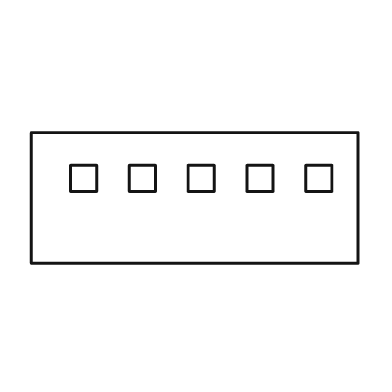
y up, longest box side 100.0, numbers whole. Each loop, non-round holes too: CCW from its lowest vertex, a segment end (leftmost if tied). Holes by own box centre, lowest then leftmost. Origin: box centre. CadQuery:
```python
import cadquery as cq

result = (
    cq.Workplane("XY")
    .moveTo(-50.0, -20.0)
    .lineTo(50.0, -20.0)
    .lineTo(50.0, 20.0)
    .lineTo(-50.0, 20.0)
    .close()
    .moveTo(-38.0, 2.0)
    .lineTo(-30.0, 2.0)
    .lineTo(-30.0, 10.0)
    .lineTo(-38.0, 10.0)
    .close()
    .moveTo(-20.0, 2.0)
    .lineTo(-12.0, 2.0)
    .lineTo(-12.0, 10.0)
    .lineTo(-20.0, 10.0)
    .close()
    .moveTo(-2.0, 2.0)
    .lineTo(6.0, 2.0)
    .lineTo(6.0, 10.0)
    .lineTo(-2.0, 10.0)
    .close()
    .moveTo(16.0, 2.0)
    .lineTo(24.0, 2.0)
    .lineTo(24.0, 10.0)
    .lineTo(16.0, 10.0)
    .close()
    .moveTo(34.0, 2.0)
    .lineTo(42.0, 2.0)
    .lineTo(42.0, 10.0)
    .lineTo(34.0, 10.0)
    .close()
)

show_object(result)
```